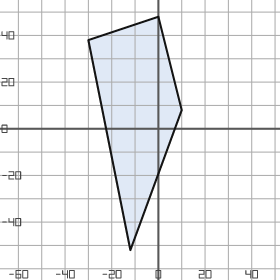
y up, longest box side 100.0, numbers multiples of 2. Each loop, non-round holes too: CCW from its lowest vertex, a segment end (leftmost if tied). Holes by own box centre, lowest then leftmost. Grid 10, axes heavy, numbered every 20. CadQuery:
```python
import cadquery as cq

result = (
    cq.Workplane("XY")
    .moveTo(-12.0, -52.0)
    .lineTo(10.0, 8.0)
    .lineTo(0.0, 48.0)
    .lineTo(-30.0, 38.0)
    .close()
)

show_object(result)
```